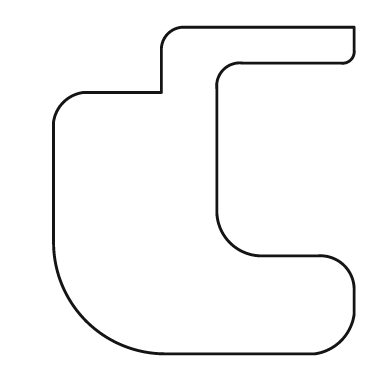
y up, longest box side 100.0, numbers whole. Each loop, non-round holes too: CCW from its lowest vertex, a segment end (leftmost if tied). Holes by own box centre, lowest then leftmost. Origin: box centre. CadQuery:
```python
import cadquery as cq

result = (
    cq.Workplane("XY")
    .moveTo(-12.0, -50.0)
    .lineTo(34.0, -50.0)
    .threePointArc((42.0, -46.0), (46.0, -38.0))
    .lineTo(46.0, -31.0)
    .threePointArc((43.0, -23.0), (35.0, -20.0))
    .lineTo(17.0, -20.0)
    .threePointArc((8.0, -16.0), (4.0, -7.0))
    .lineTo(4.0, 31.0)
    .threePointArc((6.0, 37.0), (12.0, 39.0))
    .lineTo(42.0, 39.0)
    .threePointArc((45.0, 40.0), (46.0, 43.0))
    .lineTo(46.0, 50.0)
    .lineTo(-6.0, 50.0)
    .threePointArc((-11.0, 48.0), (-13.0, 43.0))
    .lineTo(-13.0, 30.0)
    .lineTo(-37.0, 30.0)
    .threePointArc((-43.0, 27.0), (-46.0, 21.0))
    .lineTo(-46.0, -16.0)
    .threePointArc((-36.0, -40.0), (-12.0, -50.0))
    .close()
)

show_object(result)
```